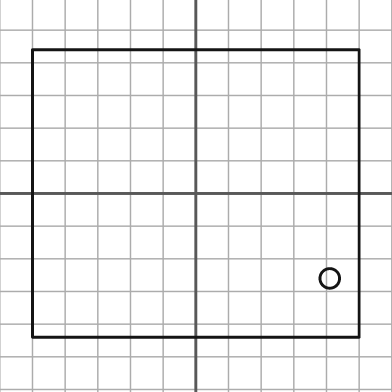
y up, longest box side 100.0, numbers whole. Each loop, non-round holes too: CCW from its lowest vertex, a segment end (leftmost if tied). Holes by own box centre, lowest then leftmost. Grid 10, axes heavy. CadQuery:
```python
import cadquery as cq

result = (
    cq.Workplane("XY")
    .moveTo(-50.0, -44.0)
    .lineTo(50.0, -44.0)
    .lineTo(50.0, 44.0)
    .lineTo(-50.0, 44.0)
    .close()
    .moveTo(41.0, -26.0)
    .circle(3.0)
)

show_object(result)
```